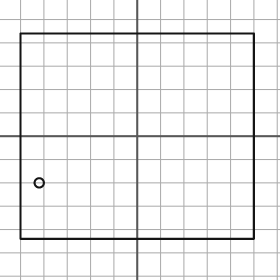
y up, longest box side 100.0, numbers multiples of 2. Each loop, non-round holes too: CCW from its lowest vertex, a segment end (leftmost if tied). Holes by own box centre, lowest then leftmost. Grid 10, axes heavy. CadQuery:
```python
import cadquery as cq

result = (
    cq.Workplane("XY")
    .moveTo(-50.0, -44.0)
    .lineTo(50.0, -44.0)
    .lineTo(50.0, 44.0)
    .lineTo(-50.0, 44.0)
    .close()
    .moveTo(-42.0, -20.0)
    .circle(2.0)
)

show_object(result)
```